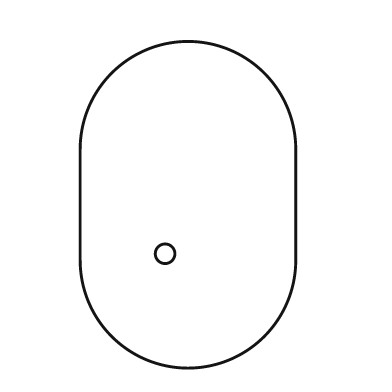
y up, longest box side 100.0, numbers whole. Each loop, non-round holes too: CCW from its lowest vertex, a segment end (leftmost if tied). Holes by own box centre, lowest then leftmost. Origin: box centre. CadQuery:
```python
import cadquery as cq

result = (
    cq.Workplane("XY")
    .moveTo(-33.0, -17.0)
    .threePointArc((0.0, -50.0), (33.0, -17.0))
    .lineTo(33.0, 17.0)
    .threePointArc((0.0, 50.0), (-33.0, 17.0))
    .close()
    .moveTo(-7.0, -15.0)
    .circle(3.0)
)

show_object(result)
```